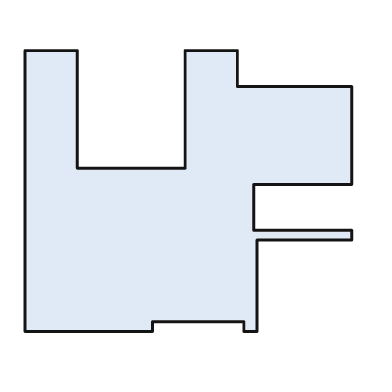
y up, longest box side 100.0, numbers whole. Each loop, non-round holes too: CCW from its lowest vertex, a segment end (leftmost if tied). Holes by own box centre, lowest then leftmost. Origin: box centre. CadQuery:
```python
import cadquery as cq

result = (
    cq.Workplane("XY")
    .moveTo(-50.0, -43.0)
    .lineTo(-11.0, -43.0)
    .lineTo(-11.0, -40.0)
    .lineTo(17.0, -40.0)
    .lineTo(17.0, -43.0)
    .lineTo(21.0, -43.0)
    .lineTo(21.0, -15.0)
    .lineTo(50.0, -15.0)
    .lineTo(50.0, -12.0)
    .lineTo(20.0, -12.0)
    .lineTo(20.0, 2.0)
    .lineTo(50.0, 2.0)
    .lineTo(50.0, 32.0)
    .lineTo(15.0, 32.0)
    .lineTo(15.0, 43.0)
    .lineTo(-1.0, 43.0)
    .lineTo(-1.0, 7.0)
    .lineTo(-34.0, 7.0)
    .lineTo(-34.0, 43.0)
    .lineTo(-50.0, 43.0)
    .close()
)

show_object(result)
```